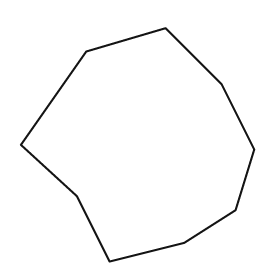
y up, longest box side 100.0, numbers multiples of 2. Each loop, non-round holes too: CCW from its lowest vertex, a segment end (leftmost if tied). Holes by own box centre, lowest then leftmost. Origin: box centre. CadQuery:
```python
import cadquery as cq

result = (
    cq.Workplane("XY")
    .moveTo(-12.0, -50.0)
    .lineTo(20.0, -42.0)
    .lineTo(42.0, -28.0)
    .lineTo(50.0, -2.0)
    .lineTo(36.0, 26.0)
    .lineTo(12.0, 50.0)
    .lineTo(-22.0, 40.0)
    .lineTo(-50.0, 0.0)
    .lineTo(-26.0, -22.0)
    .close()
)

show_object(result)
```